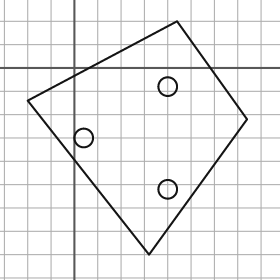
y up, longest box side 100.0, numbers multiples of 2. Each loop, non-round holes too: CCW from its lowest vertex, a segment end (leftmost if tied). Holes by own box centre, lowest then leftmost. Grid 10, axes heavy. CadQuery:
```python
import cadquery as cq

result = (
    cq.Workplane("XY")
    .moveTo(32.0, -80.0)
    .lineTo(74.0, -22.0)
    .lineTo(44.0, 20.0)
    .lineTo(-20.0, -14.0)
    .close()
    .moveTo(40.0, -52.0)
    .circle(4.0)
    .moveTo(4.0, -30.0)
    .circle(4.0)
    .moveTo(40.0, -8.0)
    .circle(4.0)
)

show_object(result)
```